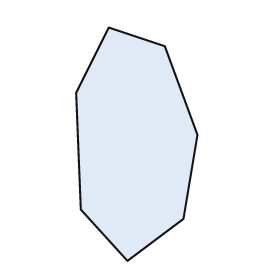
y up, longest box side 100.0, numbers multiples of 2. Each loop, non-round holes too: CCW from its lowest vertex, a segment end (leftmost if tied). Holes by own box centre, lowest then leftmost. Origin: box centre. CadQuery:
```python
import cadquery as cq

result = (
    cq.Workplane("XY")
    .moveTo(-4.0, -50.0)
    .lineTo(20.0, -32.0)
    .lineTo(26.0, 4.0)
    .lineTo(12.0, 42.0)
    .lineTo(-12.0, 50.0)
    .lineTo(-26.0, 22.0)
    .lineTo(-24.0, -28.0)
    .close()
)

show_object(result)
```